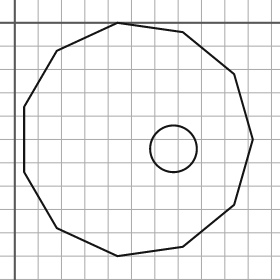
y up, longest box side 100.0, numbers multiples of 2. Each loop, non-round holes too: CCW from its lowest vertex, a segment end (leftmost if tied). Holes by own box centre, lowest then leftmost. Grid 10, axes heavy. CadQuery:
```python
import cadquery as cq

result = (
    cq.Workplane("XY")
    .moveTo(44.0, -100.0)
    .lineTo(72.0, -96.0)
    .lineTo(94.0, -78.0)
    .lineTo(102.0, -50.0)
    .lineTo(94.0, -22.0)
    .lineTo(72.0, -4.0)
    .lineTo(44.0, 0.0)
    .lineTo(18.0, -12.0)
    .lineTo(4.0, -36.0)
    .lineTo(4.0, -64.0)
    .lineTo(18.0, -88.0)
    .close()
    .moveTo(68.0, -54.0)
    .circle(10.0)
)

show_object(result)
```